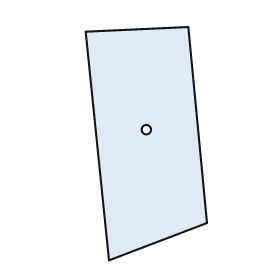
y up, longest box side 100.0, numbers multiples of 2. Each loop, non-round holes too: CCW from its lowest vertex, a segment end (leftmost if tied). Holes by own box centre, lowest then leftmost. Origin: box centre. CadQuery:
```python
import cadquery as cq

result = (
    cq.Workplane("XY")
    .moveTo(-16.0, -50.0)
    .lineTo(26.0, -34.0)
    .lineTo(18.0, 50.0)
    .lineTo(-26.0, 48.0)
    .close()
    .moveTo(0.0, 6.0)
    .circle(2.0)
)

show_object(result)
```